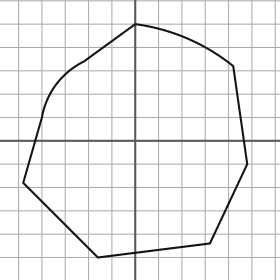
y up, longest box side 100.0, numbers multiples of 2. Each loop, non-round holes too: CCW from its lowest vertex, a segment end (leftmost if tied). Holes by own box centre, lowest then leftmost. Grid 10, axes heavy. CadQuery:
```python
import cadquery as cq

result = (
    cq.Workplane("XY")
    .moveTo(-16.0, -50.0)
    .lineTo(32.0, -44.0)
    .lineTo(48.0, -10.0)
    .lineTo(42.0, 32.0)
    .threePointArc((22.0, 44.0), (0.0, 50.0))
    .lineTo(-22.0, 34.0)
    .threePointArc((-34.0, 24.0), (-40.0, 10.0))
    .lineTo(-48.0, -18.0)
    .close()
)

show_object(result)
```